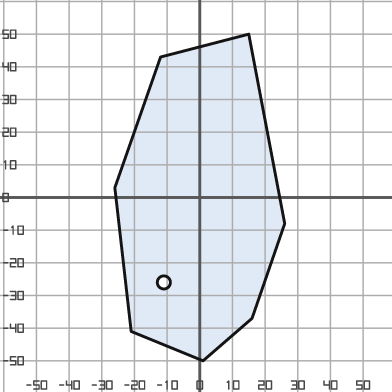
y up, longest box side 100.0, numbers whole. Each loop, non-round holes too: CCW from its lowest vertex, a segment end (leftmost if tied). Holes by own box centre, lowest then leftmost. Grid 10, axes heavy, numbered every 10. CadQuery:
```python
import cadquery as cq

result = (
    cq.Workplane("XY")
    .moveTo(1.0, -50.0)
    .lineTo(16.0, -37.0)
    .lineTo(26.0, -8.0)
    .lineTo(15.0, 50.0)
    .lineTo(-12.0, 43.0)
    .lineTo(-26.0, 3.0)
    .lineTo(-21.0, -41.0)
    .close()
    .moveTo(-11.0, -26.0)
    .circle(2.0)
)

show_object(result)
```